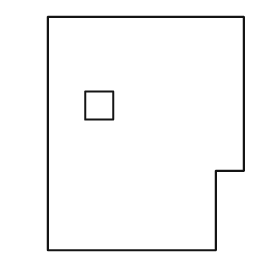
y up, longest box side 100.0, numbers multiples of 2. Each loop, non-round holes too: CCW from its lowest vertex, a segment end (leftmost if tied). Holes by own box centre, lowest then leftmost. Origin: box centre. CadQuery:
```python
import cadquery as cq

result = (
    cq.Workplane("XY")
    .moveTo(-42.0, -50.0)
    .lineTo(30.0, -50.0)
    .lineTo(30.0, -16.0)
    .lineTo(42.0, -16.0)
    .lineTo(42.0, 50.0)
    .lineTo(-42.0, 50.0)
    .close()
    .moveTo(-26.0, 6.0)
    .lineTo(-14.0, 6.0)
    .lineTo(-14.0, 18.0)
    .lineTo(-26.0, 18.0)
    .close()
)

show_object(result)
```